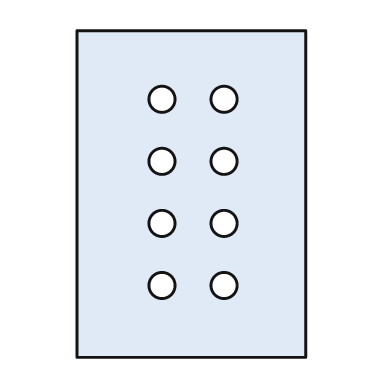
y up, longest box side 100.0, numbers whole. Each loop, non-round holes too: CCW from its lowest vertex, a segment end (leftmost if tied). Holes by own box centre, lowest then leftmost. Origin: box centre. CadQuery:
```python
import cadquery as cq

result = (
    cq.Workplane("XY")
    .moveTo(-35.0, -50.0)
    .lineTo(35.0, -50.0)
    .lineTo(35.0, 50.0)
    .lineTo(-35.0, 50.0)
    .close()
    .moveTo(-9.0, -28.0)
    .circle(4.0)
    .moveTo(10.0, -28.0)
    .circle(4.0)
    .moveTo(-9.0, -9.0)
    .circle(4.0)
    .moveTo(10.0, -9.0)
    .circle(4.0)
    .moveTo(-9.0, 10.0)
    .circle(4.0)
    .moveTo(10.0, 10.0)
    .circle(4.0)
    .moveTo(-9.0, 29.0)
    .circle(4.0)
    .moveTo(10.0, 29.0)
    .circle(4.0)
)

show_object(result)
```